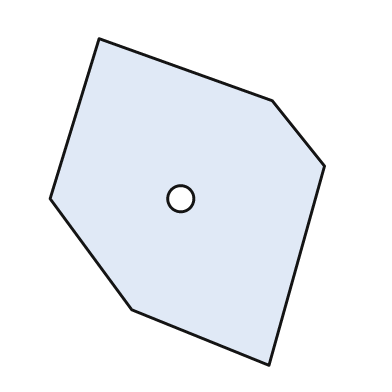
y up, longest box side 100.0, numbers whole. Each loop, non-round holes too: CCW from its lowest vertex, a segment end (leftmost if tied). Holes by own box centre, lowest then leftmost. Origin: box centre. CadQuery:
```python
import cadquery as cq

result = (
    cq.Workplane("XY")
    .moveTo(25.0, -50.0)
    .lineTo(42.0, 11.0)
    .lineTo(26.0, 31.0)
    .lineTo(-27.0, 50.0)
    .lineTo(-42.0, 1.0)
    .lineTo(-17.0, -33.0)
    .close()
    .moveTo(-2.0, 1.0)
    .circle(4.0)
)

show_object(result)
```